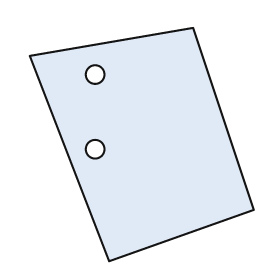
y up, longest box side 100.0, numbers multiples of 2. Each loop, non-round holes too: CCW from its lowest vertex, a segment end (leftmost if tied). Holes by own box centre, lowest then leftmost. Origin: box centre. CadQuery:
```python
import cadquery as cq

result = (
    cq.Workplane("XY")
    .moveTo(-14.0, -50.0)
    .lineTo(48.0, -28.0)
    .lineTo(22.0, 50.0)
    .lineTo(-48.0, 38.0)
    .close()
    .moveTo(-20.0, -2.0)
    .circle(4.0)
    .moveTo(-20.0, 30.0)
    .circle(4.0)
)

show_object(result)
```